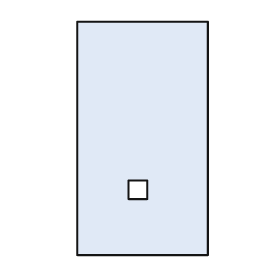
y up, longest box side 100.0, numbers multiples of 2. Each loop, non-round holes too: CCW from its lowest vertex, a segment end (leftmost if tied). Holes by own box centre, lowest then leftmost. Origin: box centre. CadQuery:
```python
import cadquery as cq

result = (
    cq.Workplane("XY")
    .moveTo(-28.0, -50.0)
    .lineTo(28.0, -50.0)
    .lineTo(28.0, 50.0)
    .lineTo(-28.0, 50.0)
    .close()
    .moveTo(-6.0, -26.0)
    .lineTo(2.0, -26.0)
    .lineTo(2.0, -18.0)
    .lineTo(-6.0, -18.0)
    .close()
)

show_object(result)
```